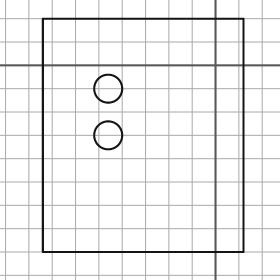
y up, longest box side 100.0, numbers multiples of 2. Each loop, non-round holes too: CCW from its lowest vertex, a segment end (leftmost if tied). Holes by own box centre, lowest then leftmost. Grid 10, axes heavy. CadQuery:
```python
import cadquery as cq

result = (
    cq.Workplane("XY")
    .moveTo(-74.0, -80.0)
    .lineTo(12.0, -80.0)
    .lineTo(12.0, 20.0)
    .lineTo(-74.0, 20.0)
    .close()
    .moveTo(-46.0, -30.0)
    .circle(6.0)
    .moveTo(-46.0, -10.0)
    .circle(6.0)
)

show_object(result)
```